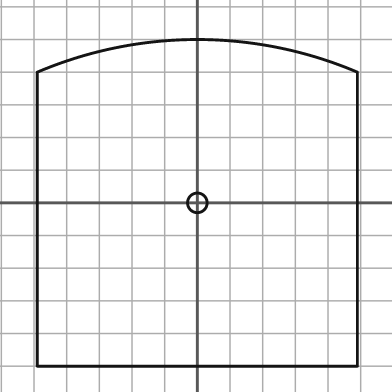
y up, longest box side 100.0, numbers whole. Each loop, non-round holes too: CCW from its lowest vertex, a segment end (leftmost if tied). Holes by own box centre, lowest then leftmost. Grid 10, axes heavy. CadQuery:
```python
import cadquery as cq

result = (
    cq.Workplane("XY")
    .moveTo(-49.0, -50.0)
    .lineTo(49.0, -50.0)
    .lineTo(49.0, 40.0)
    .threePointArc((0.0, 50.0), (-49.0, 40.0))
    .close()
    .moveTo(0.0, 0.0)
    .circle(3.0)
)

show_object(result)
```